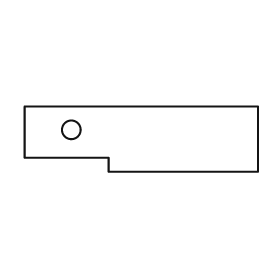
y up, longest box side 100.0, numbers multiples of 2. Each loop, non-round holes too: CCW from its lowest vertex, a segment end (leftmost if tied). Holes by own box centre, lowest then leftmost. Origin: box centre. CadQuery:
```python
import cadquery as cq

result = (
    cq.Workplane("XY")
    .moveTo(-14.0, -14.0)
    .lineTo(50.0, -14.0)
    .lineTo(50.0, 14.0)
    .lineTo(-50.0, 14.0)
    .lineTo(-50.0, -8.0)
    .lineTo(-14.0, -8.0)
    .close()
    .moveTo(-30.0, 4.0)
    .circle(4.0)
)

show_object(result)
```